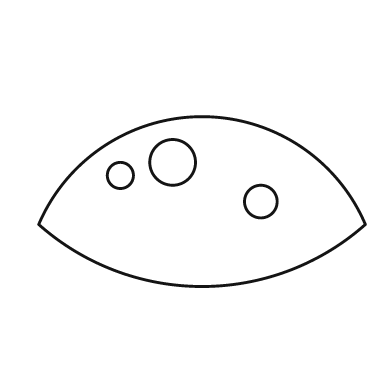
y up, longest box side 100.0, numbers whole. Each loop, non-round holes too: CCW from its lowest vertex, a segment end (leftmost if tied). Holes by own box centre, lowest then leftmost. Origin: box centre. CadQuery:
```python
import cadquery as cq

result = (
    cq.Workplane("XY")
    .moveTo(-50.0, -7.0)
    .threePointArc((0.0, -26.0), (50.0, -7.0))
    .threePointArc((0.0, 26.0), (-50.0, -7.0))
    .close()
    .moveTo(18.0, 0.0)
    .circle(5.0)
    .moveTo(-25.0, 8.0)
    .circle(4.0)
    .moveTo(-9.0, 12.0)
    .circle(7.0)
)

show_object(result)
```